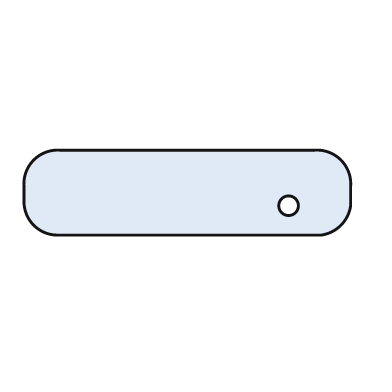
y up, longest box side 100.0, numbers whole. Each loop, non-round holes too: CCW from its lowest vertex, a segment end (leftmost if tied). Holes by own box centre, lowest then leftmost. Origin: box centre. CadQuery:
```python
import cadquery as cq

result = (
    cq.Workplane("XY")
    .moveTo(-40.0, -13.0)
    .lineTo(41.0, -13.0)
    .threePointArc((47.0, -10.0), (50.0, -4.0))
    .lineTo(50.0, 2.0)
    .threePointArc((47.0, 10.0), (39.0, 13.0))
    .lineTo(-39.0, 13.0)
    .threePointArc((-47.0, 10.0), (-50.0, 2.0))
    .lineTo(-50.0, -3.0)
    .threePointArc((-47.0, -10.0), (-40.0, -13.0))
    .close()
    .moveTo(31.0, -4.0)
    .circle(3.0)
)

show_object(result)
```